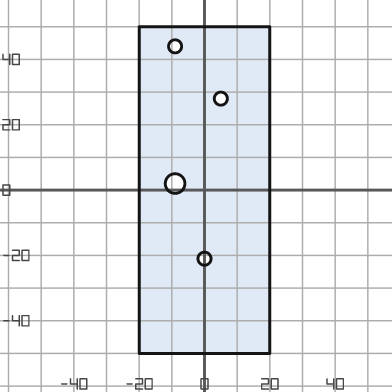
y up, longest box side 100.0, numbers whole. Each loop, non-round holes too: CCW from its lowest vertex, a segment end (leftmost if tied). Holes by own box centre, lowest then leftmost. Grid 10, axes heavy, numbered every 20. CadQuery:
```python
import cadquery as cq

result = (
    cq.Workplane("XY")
    .moveTo(-20.0, -50.0)
    .lineTo(20.0, -50.0)
    .lineTo(20.0, 50.0)
    .lineTo(-20.0, 50.0)
    .close()
    .moveTo(0.0, -21.0)
    .circle(2.0)
    .moveTo(-9.0, 2.0)
    .circle(3.0)
    .moveTo(5.0, 28.0)
    .circle(2.0)
    .moveTo(-9.0, 44.0)
    .circle(2.0)
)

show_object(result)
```